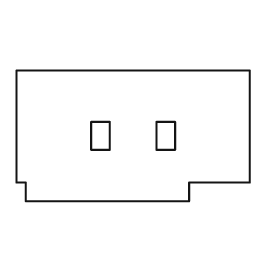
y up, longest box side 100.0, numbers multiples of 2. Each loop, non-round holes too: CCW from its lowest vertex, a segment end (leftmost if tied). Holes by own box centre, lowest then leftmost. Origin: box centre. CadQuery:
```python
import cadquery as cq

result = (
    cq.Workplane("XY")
    .moveTo(-46.0, -28.0)
    .lineTo(24.0, -28.0)
    .lineTo(24.0, -20.0)
    .lineTo(50.0, -20.0)
    .lineTo(50.0, 28.0)
    .lineTo(-50.0, 28.0)
    .lineTo(-50.0, -20.0)
    .lineTo(-46.0, -20.0)
    .close()
    .moveTo(-18.0, -6.0)
    .lineTo(-10.0, -6.0)
    .lineTo(-10.0, 6.0)
    .lineTo(-18.0, 6.0)
    .close()
    .moveTo(10.0, -6.0)
    .lineTo(18.0, -6.0)
    .lineTo(18.0, 6.0)
    .lineTo(10.0, 6.0)
    .close()
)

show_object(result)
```